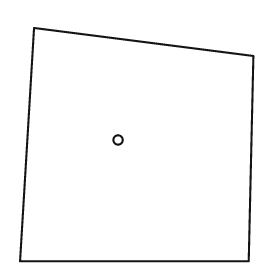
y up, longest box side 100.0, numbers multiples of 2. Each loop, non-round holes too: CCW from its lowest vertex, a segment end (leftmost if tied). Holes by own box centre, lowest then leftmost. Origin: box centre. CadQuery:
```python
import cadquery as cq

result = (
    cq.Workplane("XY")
    .moveTo(-50.0, -50.0)
    .lineTo(48.0, -50.0)
    .lineTo(50.0, 38.0)
    .lineTo(-44.0, 50.0)
    .close()
    .moveTo(-8.0, 2.0)
    .circle(2.0)
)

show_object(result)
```